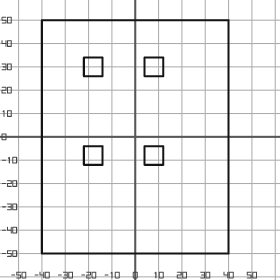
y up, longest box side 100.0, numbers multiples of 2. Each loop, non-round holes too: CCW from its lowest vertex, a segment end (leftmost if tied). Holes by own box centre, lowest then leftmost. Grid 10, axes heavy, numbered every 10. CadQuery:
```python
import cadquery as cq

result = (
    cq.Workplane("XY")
    .moveTo(-40.0, -50.0)
    .lineTo(40.0, -50.0)
    .lineTo(40.0, 50.0)
    .lineTo(-40.0, 50.0)
    .close()
    .moveTo(-22.0, -12.0)
    .lineTo(-14.0, -12.0)
    .lineTo(-14.0, -4.0)
    .lineTo(-22.0, -4.0)
    .close()
    .moveTo(4.0, -12.0)
    .lineTo(12.0, -12.0)
    .lineTo(12.0, -4.0)
    .lineTo(4.0, -4.0)
    .close()
    .moveTo(-22.0, 26.0)
    .lineTo(-14.0, 26.0)
    .lineTo(-14.0, 34.0)
    .lineTo(-22.0, 34.0)
    .close()
    .moveTo(4.0, 26.0)
    .lineTo(12.0, 26.0)
    .lineTo(12.0, 34.0)
    .lineTo(4.0, 34.0)
    .close()
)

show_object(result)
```